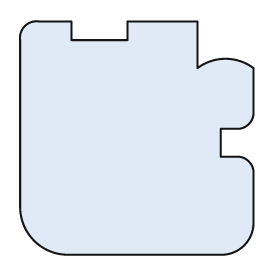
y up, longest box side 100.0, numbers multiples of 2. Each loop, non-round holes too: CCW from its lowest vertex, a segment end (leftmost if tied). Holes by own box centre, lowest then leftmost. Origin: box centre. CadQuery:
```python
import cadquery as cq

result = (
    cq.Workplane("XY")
    .moveTo(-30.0, -50.0)
    .lineTo(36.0, -50.0)
    .threePointArc((46.0, -46.0), (50.0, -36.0))
    .lineTo(50.0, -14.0)
    .threePointArc((48.0, -10.0), (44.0, -8.0))
    .lineTo(36.0, -8.0)
    .lineTo(36.0, 4.0)
    .lineTo(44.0, 4.0)
    .threePointArc((48.0, 6.0), (50.0, 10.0))
    .lineTo(50.0, 30.0)
    .threePointArc((38.0, 34.0), (26.0, 30.0))
    .lineTo(26.0, 50.0)
    .lineTo(-4.0, 50.0)
    .lineTo(-4.0, 42.0)
    .lineTo(-28.0, 42.0)
    .lineTo(-28.0, 50.0)
    .lineTo(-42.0, 50.0)
    .threePointArc((-48.0, 48.0), (-50.0, 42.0))
    .lineTo(-50.0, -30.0)
    .threePointArc((-44.0, -44.0), (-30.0, -50.0))
    .close()
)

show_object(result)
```